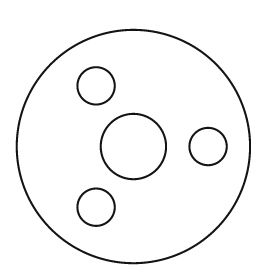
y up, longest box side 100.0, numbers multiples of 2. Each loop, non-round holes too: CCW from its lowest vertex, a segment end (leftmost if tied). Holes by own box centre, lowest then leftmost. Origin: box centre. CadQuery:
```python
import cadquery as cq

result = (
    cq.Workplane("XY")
    .moveTo(0.0, 0.0)
    .circle(50.0)
    .moveTo(-16.0, -26.0)
    .circle(8.0)
    .moveTo(0.0, 0.0)
    .circle(14.0)
    .moveTo(32.0, 0.0)
    .circle(8.0)
    .moveTo(-16.0, 26.0)
    .circle(8.0)
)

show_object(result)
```